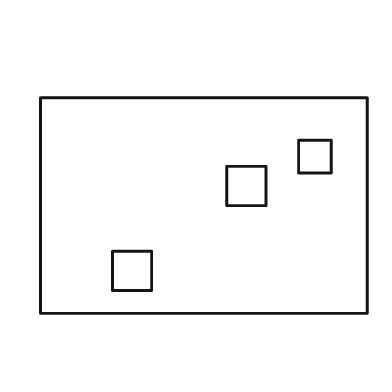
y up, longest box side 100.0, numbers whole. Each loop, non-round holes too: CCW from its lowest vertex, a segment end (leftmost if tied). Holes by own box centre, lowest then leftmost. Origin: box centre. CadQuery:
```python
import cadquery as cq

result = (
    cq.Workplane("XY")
    .moveTo(-50.0, -33.0)
    .lineTo(50.0, -33.0)
    .lineTo(50.0, 33.0)
    .lineTo(-50.0, 33.0)
    .close()
    .moveTo(-28.0, -26.0)
    .lineTo(-16.0, -26.0)
    .lineTo(-16.0, -14.0)
    .lineTo(-28.0, -14.0)
    .close()
    .moveTo(7.0, 0.0)
    .lineTo(19.0, 0.0)
    .lineTo(19.0, 12.0)
    .lineTo(7.0, 12.0)
    .close()
    .moveTo(29.0, 10.0)
    .lineTo(39.0, 10.0)
    .lineTo(39.0, 20.0)
    .lineTo(29.0, 20.0)
    .close()
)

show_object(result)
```